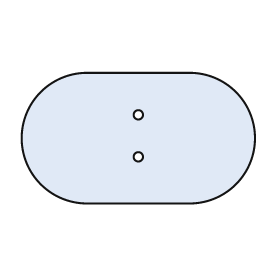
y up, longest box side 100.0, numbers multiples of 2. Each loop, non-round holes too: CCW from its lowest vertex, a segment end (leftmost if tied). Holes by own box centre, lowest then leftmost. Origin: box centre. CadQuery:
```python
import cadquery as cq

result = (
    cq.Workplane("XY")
    .moveTo(-22.0, -28.0)
    .lineTo(22.0, -28.0)
    .threePointArc((50.0, 0.0), (22.0, 28.0))
    .lineTo(-22.0, 28.0)
    .threePointArc((-50.0, 0.0), (-22.0, -28.0))
    .close()
    .moveTo(0.0, -8.0)
    .circle(2.0)
    .moveTo(0.0, 10.0)
    .circle(2.0)
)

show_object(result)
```